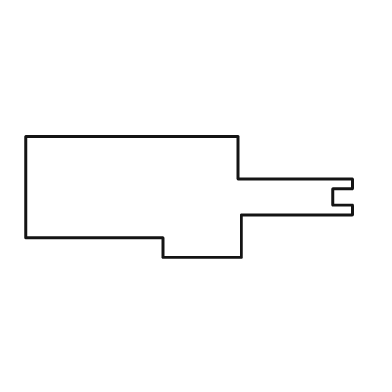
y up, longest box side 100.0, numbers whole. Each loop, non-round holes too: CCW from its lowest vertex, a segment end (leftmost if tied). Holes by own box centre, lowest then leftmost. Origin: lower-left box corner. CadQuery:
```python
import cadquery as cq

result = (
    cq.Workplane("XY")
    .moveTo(42.0, 0.0)
    .lineTo(66.0, 0.0)
    .lineTo(66.0, 13.0)
    .lineTo(100.0, 13.0)
    .lineTo(100.0, 16.0)
    .lineTo(94.0, 16.0)
    .lineTo(94.0, 21.0)
    .lineTo(100.0, 21.0)
    .lineTo(100.0, 24.0)
    .lineTo(65.0, 24.0)
    .lineTo(65.0, 37.0)
    .lineTo(0.0, 37.0)
    .lineTo(0.0, 6.0)
    .lineTo(42.0, 6.0)
    .close()
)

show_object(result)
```